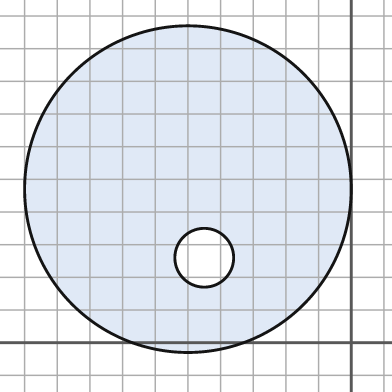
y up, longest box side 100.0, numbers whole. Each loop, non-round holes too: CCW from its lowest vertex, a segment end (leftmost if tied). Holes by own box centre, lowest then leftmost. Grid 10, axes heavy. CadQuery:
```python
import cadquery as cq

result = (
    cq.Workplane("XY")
    .moveTo(-50.0, 47.0)
    .circle(50.0)
    .moveTo(-45.0, 26.0)
    .circle(9.0)
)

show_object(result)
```